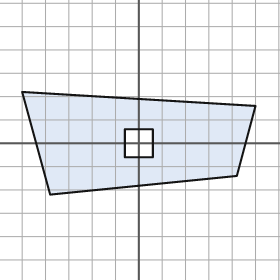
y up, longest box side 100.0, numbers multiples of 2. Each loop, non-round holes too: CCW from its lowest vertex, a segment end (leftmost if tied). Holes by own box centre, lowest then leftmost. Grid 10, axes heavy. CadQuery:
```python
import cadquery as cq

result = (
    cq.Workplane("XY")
    .moveTo(-38.0, -22.0)
    .lineTo(42.0, -14.0)
    .lineTo(50.0, 16.0)
    .lineTo(-50.0, 22.0)
    .close()
    .moveTo(-6.0, -6.0)
    .lineTo(6.0, -6.0)
    .lineTo(6.0, 6.0)
    .lineTo(-6.0, 6.0)
    .close()
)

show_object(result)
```